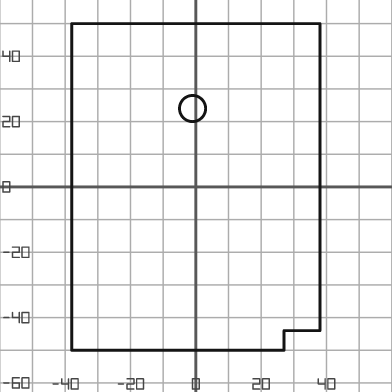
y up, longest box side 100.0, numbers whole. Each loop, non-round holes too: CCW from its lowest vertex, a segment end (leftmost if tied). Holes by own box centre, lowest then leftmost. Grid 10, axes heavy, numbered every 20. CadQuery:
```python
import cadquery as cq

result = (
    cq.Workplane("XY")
    .moveTo(-38.0, -50.0)
    .lineTo(27.0, -50.0)
    .lineTo(27.0, -44.0)
    .lineTo(38.0, -44.0)
    .lineTo(38.0, 50.0)
    .lineTo(-38.0, 50.0)
    .close()
    .moveTo(-1.0, 24.0)
    .circle(4.0)
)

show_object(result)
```